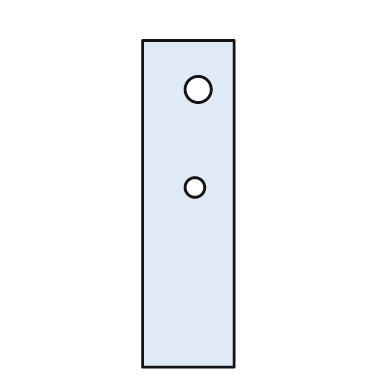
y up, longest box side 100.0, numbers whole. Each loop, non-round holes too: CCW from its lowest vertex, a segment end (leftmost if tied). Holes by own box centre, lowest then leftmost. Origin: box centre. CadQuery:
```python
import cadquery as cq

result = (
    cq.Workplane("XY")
    .moveTo(-14.0, -50.0)
    .lineTo(14.0, -50.0)
    .lineTo(14.0, 50.0)
    .lineTo(-14.0, 50.0)
    .close()
    .moveTo(2.0, 5.0)
    .circle(3.0)
    .moveTo(3.0, 35.0)
    .circle(4.0)
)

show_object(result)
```